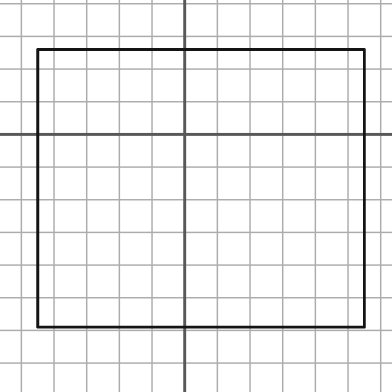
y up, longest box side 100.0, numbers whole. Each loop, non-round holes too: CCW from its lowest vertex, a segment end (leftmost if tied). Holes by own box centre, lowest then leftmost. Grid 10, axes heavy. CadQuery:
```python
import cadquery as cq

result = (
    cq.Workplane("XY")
    .moveTo(-45.0, -59.0)
    .lineTo(55.0, -59.0)
    .lineTo(55.0, 26.0)
    .lineTo(-45.0, 26.0)
    .close()
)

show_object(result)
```